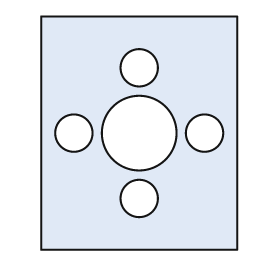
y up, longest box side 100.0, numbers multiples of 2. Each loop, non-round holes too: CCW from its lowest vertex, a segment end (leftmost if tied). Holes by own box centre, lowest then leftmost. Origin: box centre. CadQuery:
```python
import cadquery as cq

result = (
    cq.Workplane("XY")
    .moveTo(-42.0, -50.0)
    .lineTo(42.0, -50.0)
    .lineTo(42.0, 50.0)
    .lineTo(-42.0, 50.0)
    .close()
    .moveTo(0.0, -28.0)
    .circle(8.0)
    .moveTo(-28.0, 0.0)
    .circle(8.0)
    .moveTo(0.0, 0.0)
    .circle(16.0)
    .moveTo(28.0, 0.0)
    .circle(8.0)
    .moveTo(0.0, 28.0)
    .circle(8.0)
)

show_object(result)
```